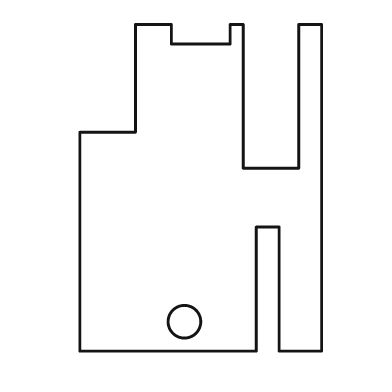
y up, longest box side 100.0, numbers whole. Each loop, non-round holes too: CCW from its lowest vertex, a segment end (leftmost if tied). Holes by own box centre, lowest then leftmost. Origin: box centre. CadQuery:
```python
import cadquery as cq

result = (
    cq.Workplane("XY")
    .moveTo(-37.0, -50.0)
    .lineTo(17.0, -50.0)
    .lineTo(17.0, -12.0)
    .lineTo(24.0, -12.0)
    .lineTo(24.0, -50.0)
    .lineTo(37.0, -50.0)
    .lineTo(37.0, 50.0)
    .lineTo(30.0, 50.0)
    .lineTo(30.0, 6.0)
    .lineTo(13.0, 6.0)
    .lineTo(13.0, 50.0)
    .lineTo(9.0, 50.0)
    .lineTo(9.0, 44.0)
    .lineTo(-9.0, 44.0)
    .lineTo(-9.0, 50.0)
    .lineTo(-20.0, 50.0)
    .lineTo(-20.0, 17.0)
    .lineTo(-37.0, 17.0)
    .close()
    .moveTo(-5.0, -41.0)
    .circle(5.0)
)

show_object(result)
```